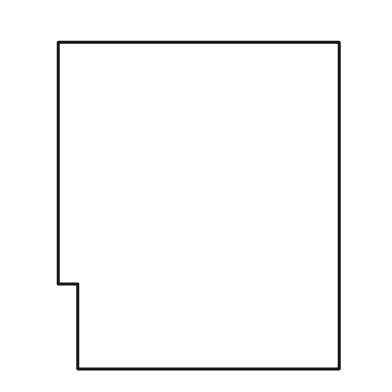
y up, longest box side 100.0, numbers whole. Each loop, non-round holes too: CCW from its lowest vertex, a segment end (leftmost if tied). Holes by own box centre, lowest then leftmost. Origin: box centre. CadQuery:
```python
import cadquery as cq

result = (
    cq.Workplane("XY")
    .moveTo(-37.0, -50.0)
    .lineTo(43.0, -50.0)
    .lineTo(43.0, 50.0)
    .lineTo(-43.0, 50.0)
    .lineTo(-43.0, -24.0)
    .lineTo(-37.0, -24.0)
    .close()
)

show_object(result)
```